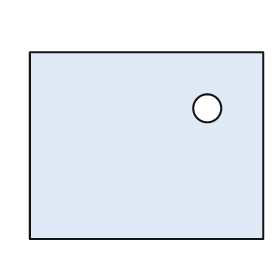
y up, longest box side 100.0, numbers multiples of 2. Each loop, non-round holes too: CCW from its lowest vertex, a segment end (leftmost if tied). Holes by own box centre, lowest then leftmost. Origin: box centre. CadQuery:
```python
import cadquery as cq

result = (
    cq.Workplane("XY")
    .moveTo(-50.0, -40.0)
    .lineTo(50.0, -40.0)
    .lineTo(50.0, 40.0)
    .lineTo(-50.0, 40.0)
    .close()
    .moveTo(26.0, 16.0)
    .circle(6.0)
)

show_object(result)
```